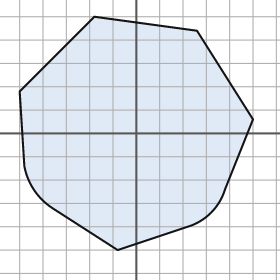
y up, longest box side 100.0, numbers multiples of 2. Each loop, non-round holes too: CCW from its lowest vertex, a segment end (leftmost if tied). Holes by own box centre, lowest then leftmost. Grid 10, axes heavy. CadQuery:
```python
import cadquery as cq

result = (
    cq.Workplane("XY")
    .moveTo(-8.0, -50.0)
    .lineTo(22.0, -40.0)
    .threePointArc((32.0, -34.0), (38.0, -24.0))
    .lineTo(50.0, 6.0)
    .lineTo(26.0, 44.0)
    .lineTo(-18.0, 50.0)
    .lineTo(-50.0, 18.0)
    .lineTo(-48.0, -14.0)
    .threePointArc((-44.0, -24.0), (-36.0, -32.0))
    .close()
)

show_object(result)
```